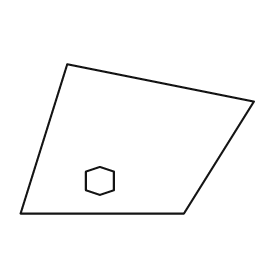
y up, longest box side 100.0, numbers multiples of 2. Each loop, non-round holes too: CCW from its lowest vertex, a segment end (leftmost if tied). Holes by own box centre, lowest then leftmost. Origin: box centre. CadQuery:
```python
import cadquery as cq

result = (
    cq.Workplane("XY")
    .moveTo(-50.0, -32.0)
    .lineTo(20.0, -32.0)
    .lineTo(50.0, 16.0)
    .lineTo(-30.0, 32.0)
    .close()
    .moveTo(-16.0, -24.0)
    .lineTo(-10.0, -22.0)
    .lineTo(-10.0, -14.0)
    .lineTo(-16.0, -12.0)
    .lineTo(-22.0, -14.0)
    .lineTo(-22.0, -22.0)
    .close()
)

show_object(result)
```